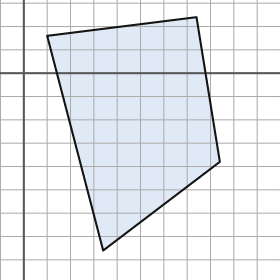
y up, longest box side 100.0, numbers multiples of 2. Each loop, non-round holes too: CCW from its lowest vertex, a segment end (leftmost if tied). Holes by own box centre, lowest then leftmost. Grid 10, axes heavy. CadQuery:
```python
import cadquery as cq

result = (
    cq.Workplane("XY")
    .moveTo(34.0, -76.0)
    .lineTo(84.0, -38.0)
    .lineTo(74.0, 24.0)
    .lineTo(10.0, 16.0)
    .close()
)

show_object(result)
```